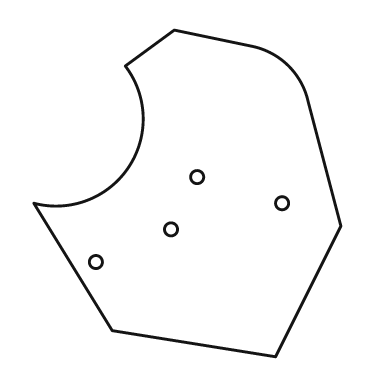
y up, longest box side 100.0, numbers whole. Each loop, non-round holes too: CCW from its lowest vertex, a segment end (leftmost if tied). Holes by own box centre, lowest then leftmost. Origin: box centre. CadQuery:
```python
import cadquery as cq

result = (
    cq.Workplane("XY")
    .moveTo(27.0, -50.0)
    .lineTo(47.0, -10.0)
    .lineTo(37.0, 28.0)
    .threePointArc((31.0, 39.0), (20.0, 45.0))
    .lineTo(-4.0, 50.0)
    .lineTo(-19.0, 39.0)
    .threePointArc((-18.0, 8.0), (-47.0, -3.0))
    .lineTo(-23.0, -42.0)
    .close()
    .moveTo(-28.0, -21.0)
    .circle(2.0)
    .moveTo(-5.0, -11.0)
    .circle(2.0)
    .moveTo(29.0, -3.0)
    .circle(2.0)
    .moveTo(3.0, 5.0)
    .circle(2.0)
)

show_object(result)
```